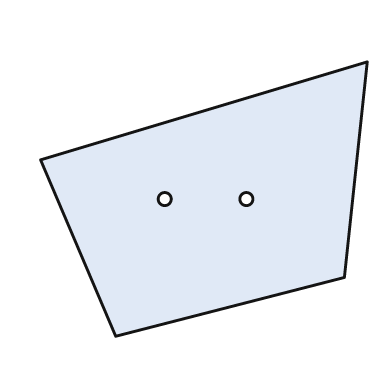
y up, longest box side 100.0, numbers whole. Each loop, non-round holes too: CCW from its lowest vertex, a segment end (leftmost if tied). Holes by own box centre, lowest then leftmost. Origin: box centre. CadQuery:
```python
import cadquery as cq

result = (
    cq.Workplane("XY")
    .moveTo(-27.0, -42.0)
    .lineTo(43.0, -24.0)
    .lineTo(50.0, 42.0)
    .lineTo(-50.0, 12.0)
    .close()
    .moveTo(-12.0, 0.0)
    .circle(2.0)
    .moveTo(13.0, 0.0)
    .circle(2.0)
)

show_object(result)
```